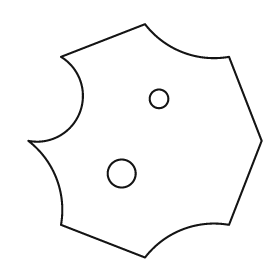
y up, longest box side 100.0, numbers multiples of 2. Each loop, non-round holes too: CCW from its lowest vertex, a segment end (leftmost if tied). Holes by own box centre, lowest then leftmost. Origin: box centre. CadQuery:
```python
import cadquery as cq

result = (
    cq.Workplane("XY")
    .moveTo(0.0, -50.0)
    .threePointArc((16.0, -38.0), (36.0, -36.0))
    .lineTo(50.0, 0.0)
    .lineTo(36.0, 36.0)
    .threePointArc((16.0, 38.0), (0.0, 50.0))
    .lineTo(-36.0, 36.0)
    .threePointArc((-28.0, 12.0), (-50.0, 0.0))
    .threePointArc((-38.0, -16.0), (-36.0, -36.0))
    .close()
    .moveTo(-10.0, -14.0)
    .circle(6.0)
    .moveTo(6.0, 18.0)
    .circle(4.0)
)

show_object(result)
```